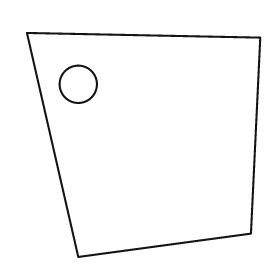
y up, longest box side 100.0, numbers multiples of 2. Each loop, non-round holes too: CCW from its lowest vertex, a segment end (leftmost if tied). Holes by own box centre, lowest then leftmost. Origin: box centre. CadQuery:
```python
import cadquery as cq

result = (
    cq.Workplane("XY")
    .moveTo(-28.0, -48.0)
    .lineTo(46.0, -38.0)
    .lineTo(50.0, 46.0)
    .lineTo(-50.0, 48.0)
    .close()
    .moveTo(-28.0, 26.0)
    .circle(8.0)
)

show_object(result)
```